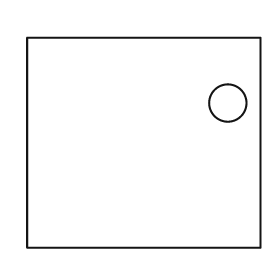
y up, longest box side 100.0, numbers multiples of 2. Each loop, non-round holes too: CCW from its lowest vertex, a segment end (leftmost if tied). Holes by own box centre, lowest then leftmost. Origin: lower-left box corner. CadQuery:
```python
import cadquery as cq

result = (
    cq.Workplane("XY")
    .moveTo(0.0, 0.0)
    .lineTo(100.0, 0.0)
    .lineTo(100.0, 90.0)
    .lineTo(0.0, 90.0)
    .close()
    .moveTo(86.0, 62.0)
    .circle(8.0)
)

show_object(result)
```